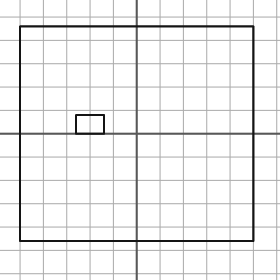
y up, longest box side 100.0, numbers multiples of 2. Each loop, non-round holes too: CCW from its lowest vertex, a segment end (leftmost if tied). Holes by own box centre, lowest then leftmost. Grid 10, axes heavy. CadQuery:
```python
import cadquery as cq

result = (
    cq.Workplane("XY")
    .moveTo(-50.0, -46.0)
    .lineTo(50.0, -46.0)
    .lineTo(50.0, 46.0)
    .lineTo(-50.0, 46.0)
    .close()
    .moveTo(-26.0, 0.0)
    .lineTo(-14.0, 0.0)
    .lineTo(-14.0, 8.0)
    .lineTo(-26.0, 8.0)
    .close()
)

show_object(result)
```